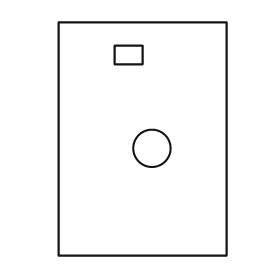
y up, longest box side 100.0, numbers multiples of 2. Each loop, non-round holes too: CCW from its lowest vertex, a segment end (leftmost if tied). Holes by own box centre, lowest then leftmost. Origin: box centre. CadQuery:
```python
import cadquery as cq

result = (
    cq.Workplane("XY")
    .moveTo(-36.0, -50.0)
    .lineTo(36.0, -50.0)
    .lineTo(36.0, 50.0)
    .lineTo(-36.0, 50.0)
    .close()
    .moveTo(4.0, -4.0)
    .circle(8.0)
    .moveTo(-12.0, 32.0)
    .lineTo(0.0, 32.0)
    .lineTo(0.0, 40.0)
    .lineTo(-12.0, 40.0)
    .close()
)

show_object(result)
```